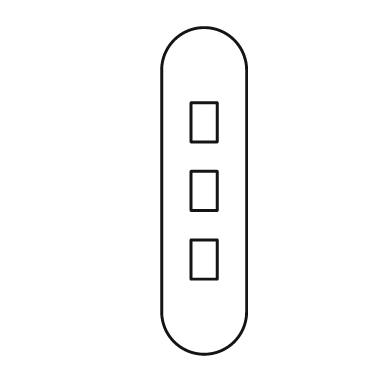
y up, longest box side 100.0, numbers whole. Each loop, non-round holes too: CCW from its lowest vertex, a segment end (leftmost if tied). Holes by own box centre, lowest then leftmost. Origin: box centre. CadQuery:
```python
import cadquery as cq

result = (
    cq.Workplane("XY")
    .moveTo(-13.0, -37.0)
    .threePointArc((0.0, -50.0), (13.0, -37.0))
    .lineTo(13.0, 37.0)
    .threePointArc((0.0, 50.0), (-13.0, 37.0))
    .close()
    .moveTo(-4.0, -27.0)
    .lineTo(4.0, -27.0)
    .lineTo(4.0, -15.0)
    .lineTo(-4.0, -15.0)
    .close()
    .moveTo(-4.0, -6.0)
    .lineTo(4.0, -6.0)
    .lineTo(4.0, 6.0)
    .lineTo(-4.0, 6.0)
    .close()
    .moveTo(-4.0, 15.0)
    .lineTo(4.0, 15.0)
    .lineTo(4.0, 27.0)
    .lineTo(-4.0, 27.0)
    .close()
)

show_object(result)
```